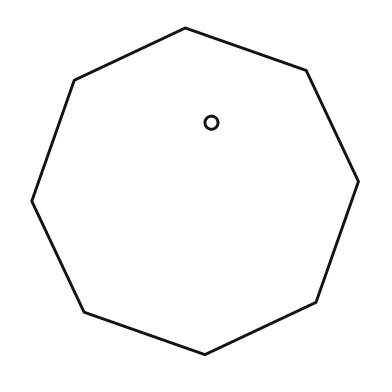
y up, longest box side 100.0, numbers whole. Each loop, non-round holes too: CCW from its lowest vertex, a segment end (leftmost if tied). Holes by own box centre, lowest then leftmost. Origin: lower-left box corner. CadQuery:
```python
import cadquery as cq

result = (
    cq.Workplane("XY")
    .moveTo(53.0, 0.0)
    .lineTo(87.0, 16.0)
    .lineTo(100.0, 53.0)
    .lineTo(84.0, 87.0)
    .lineTo(47.0, 100.0)
    .lineTo(13.0, 84.0)
    .lineTo(0.0, 47.0)
    .lineTo(16.0, 13.0)
    .close()
    .moveTo(55.0, 71.0)
    .circle(2.0)
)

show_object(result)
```